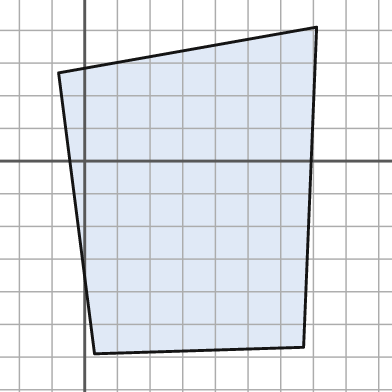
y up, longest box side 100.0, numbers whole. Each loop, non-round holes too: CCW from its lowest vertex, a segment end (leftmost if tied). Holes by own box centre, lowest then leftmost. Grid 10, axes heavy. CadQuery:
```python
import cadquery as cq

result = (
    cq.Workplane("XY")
    .moveTo(3.0, -59.0)
    .lineTo(67.0, -57.0)
    .lineTo(71.0, 41.0)
    .lineTo(-8.0, 27.0)
    .close()
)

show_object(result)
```